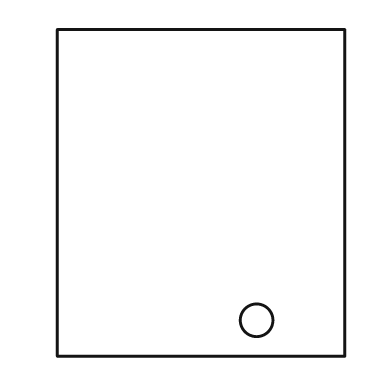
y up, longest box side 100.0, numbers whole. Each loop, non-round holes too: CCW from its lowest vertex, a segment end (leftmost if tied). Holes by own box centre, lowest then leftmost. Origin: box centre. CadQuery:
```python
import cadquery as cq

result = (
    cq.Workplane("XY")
    .moveTo(-44.0, -50.0)
    .lineTo(44.0, -50.0)
    .lineTo(44.0, 50.0)
    .lineTo(-44.0, 50.0)
    .close()
    .moveTo(17.0, -39.0)
    .circle(5.0)
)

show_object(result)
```